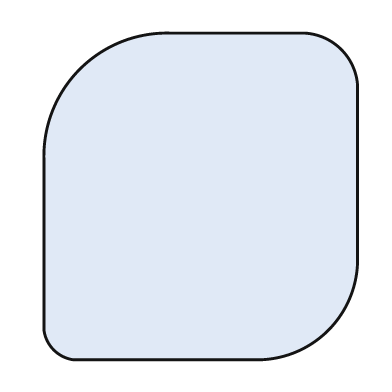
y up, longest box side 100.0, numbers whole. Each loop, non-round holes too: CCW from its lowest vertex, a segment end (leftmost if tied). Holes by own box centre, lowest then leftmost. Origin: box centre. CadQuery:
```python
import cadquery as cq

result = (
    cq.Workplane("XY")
    .moveTo(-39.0, -50.0)
    .lineTo(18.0, -50.0)
    .threePointArc((39.0, -41.0), (48.0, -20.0))
    .lineTo(48.0, 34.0)
    .threePointArc((43.0, 45.0), (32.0, 50.0))
    .lineTo(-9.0, 50.0)
    .threePointArc((-37.0, 39.0), (-48.0, 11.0))
    .lineTo(-48.0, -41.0)
    .threePointArc((-45.0, -47.0), (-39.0, -50.0))
    .close()
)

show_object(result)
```